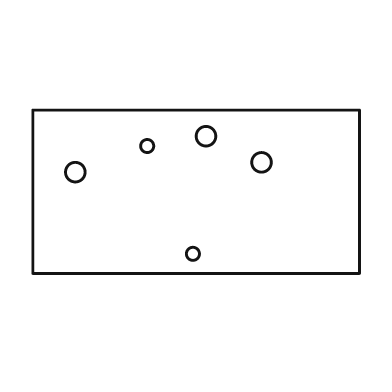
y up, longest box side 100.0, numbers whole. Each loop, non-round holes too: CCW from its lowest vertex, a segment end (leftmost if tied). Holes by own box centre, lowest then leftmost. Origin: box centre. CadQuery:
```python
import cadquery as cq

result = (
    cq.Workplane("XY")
    .moveTo(-50.0, -25.0)
    .lineTo(50.0, -25.0)
    .lineTo(50.0, 25.0)
    .lineTo(-50.0, 25.0)
    .close()
    .moveTo(-1.0, -19.0)
    .circle(2.0)
    .moveTo(-37.0, 6.0)
    .circle(3.0)
    .moveTo(20.0, 9.0)
    .circle(3.0)
    .moveTo(-15.0, 14.0)
    .circle(2.0)
    .moveTo(3.0, 17.0)
    .circle(3.0)
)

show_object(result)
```